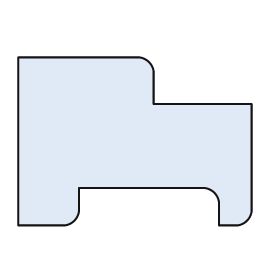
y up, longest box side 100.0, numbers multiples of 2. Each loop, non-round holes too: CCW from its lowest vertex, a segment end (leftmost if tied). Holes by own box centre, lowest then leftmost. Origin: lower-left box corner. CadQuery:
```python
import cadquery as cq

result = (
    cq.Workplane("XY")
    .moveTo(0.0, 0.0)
    .lineTo(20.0, 0.0)
    .threePointArc((24.0, 2.0), (26.0, 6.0))
    .lineTo(26.0, 16.0)
    .lineTo(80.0, 16.0)
    .threePointArc((84.0, 14.0), (86.0, 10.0))
    .lineTo(86.0, 0.0)
    .lineTo(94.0, 0.0)
    .threePointArc((98.0, 2.0), (100.0, 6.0))
    .lineTo(100.0, 52.0)
    .lineTo(58.0, 52.0)
    .lineTo(58.0, 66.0)
    .threePointArc((56.0, 70.0), (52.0, 72.0))
    .lineTo(0.0, 72.0)
    .close()
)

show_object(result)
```